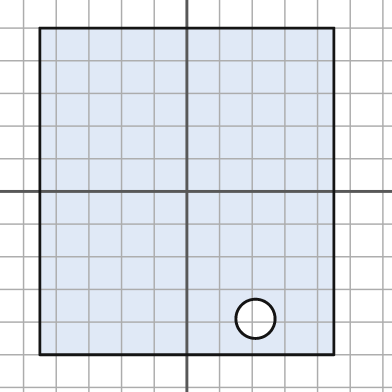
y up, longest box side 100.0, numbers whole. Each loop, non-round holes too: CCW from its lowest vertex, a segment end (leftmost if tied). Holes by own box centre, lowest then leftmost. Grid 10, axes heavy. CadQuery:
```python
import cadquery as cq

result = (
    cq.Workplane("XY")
    .moveTo(-45.0, -50.0)
    .lineTo(45.0, -50.0)
    .lineTo(45.0, 50.0)
    .lineTo(-45.0, 50.0)
    .close()
    .moveTo(21.0, -39.0)
    .circle(6.0)
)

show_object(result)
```